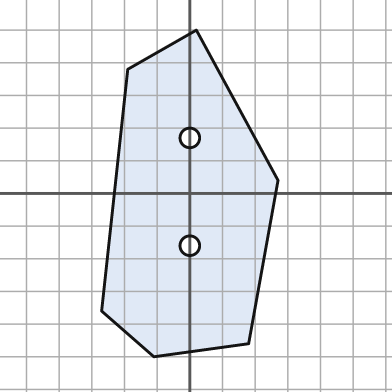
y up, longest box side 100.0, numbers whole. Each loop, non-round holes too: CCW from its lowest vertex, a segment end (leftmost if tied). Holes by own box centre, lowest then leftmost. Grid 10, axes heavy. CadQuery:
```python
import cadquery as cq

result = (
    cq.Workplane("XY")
    .moveTo(-11.0, -50.0)
    .lineTo(18.0, -46.0)
    .lineTo(27.0, 4.0)
    .lineTo(2.0, 50.0)
    .lineTo(-19.0, 38.0)
    .lineTo(-27.0, -36.0)
    .close()
    .moveTo(0.0, -16.0)
    .circle(3.0)
    .moveTo(0.0, 17.0)
    .circle(3.0)
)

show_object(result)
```